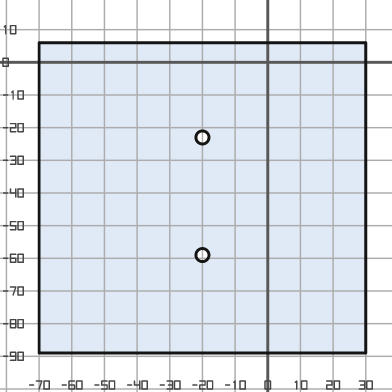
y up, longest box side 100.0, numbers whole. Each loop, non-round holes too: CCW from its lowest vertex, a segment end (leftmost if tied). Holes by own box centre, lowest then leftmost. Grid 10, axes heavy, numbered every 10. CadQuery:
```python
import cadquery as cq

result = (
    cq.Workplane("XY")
    .moveTo(-70.0, -89.0)
    .lineTo(30.0, -89.0)
    .lineTo(30.0, 6.0)
    .lineTo(-70.0, 6.0)
    .close()
    .moveTo(-20.0, -59.0)
    .circle(2.0)
    .moveTo(-20.0, -23.0)
    .circle(2.0)
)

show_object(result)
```